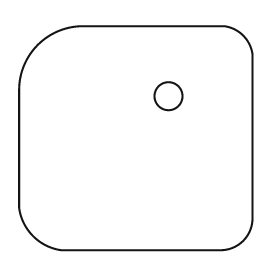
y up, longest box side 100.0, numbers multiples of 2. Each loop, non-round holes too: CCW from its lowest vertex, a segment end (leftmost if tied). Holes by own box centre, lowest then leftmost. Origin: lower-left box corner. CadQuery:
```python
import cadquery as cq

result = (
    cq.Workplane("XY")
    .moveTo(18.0, 0.0)
    .lineTo(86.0, 0.0)
    .threePointArc((96.0, 4.0), (100.0, 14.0))
    .lineTo(100.0, 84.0)
    .threePointArc((96.0, 92.0), (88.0, 96.0))
    .lineTo(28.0, 96.0)
    .threePointArc((8.0, 88.0), (0.0, 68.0))
    .lineTo(0.0, 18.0)
    .threePointArc((6.0, 6.0), (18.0, 0.0))
    .close()
    .moveTo(64.0, 66.0)
    .circle(6.0)
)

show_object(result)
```